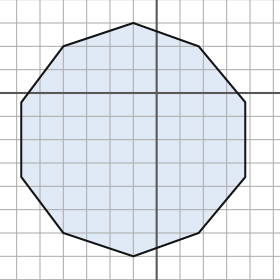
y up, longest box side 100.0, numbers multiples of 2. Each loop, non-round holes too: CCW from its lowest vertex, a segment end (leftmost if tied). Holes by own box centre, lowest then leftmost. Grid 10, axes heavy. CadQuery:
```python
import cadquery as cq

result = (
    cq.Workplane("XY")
    .moveTo(-10.0, -70.0)
    .lineTo(18.0, -60.0)
    .lineTo(38.0, -36.0)
    .lineTo(38.0, -4.0)
    .lineTo(18.0, 20.0)
    .lineTo(-10.0, 30.0)
    .lineTo(-40.0, 20.0)
    .lineTo(-58.0, -4.0)
    .lineTo(-58.0, -36.0)
    .lineTo(-40.0, -60.0)
    .close()
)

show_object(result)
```